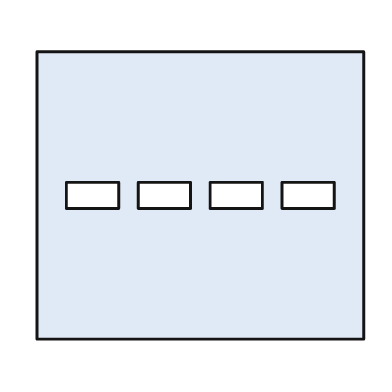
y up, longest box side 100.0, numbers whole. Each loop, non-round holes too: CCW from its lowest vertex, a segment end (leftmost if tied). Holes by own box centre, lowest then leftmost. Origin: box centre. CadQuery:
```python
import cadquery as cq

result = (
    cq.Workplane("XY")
    .moveTo(-50.0, -44.0)
    .lineTo(50.0, -44.0)
    .lineTo(50.0, 44.0)
    .lineTo(-50.0, 44.0)
    .close()
    .moveTo(-41.0, -4.0)
    .lineTo(-25.0, -4.0)
    .lineTo(-25.0, 4.0)
    .lineTo(-41.0, 4.0)
    .close()
    .moveTo(-19.0, -4.0)
    .lineTo(-3.0, -4.0)
    .lineTo(-3.0, 4.0)
    .lineTo(-19.0, 4.0)
    .close()
    .moveTo(3.0, -4.0)
    .lineTo(19.0, -4.0)
    .lineTo(19.0, 4.0)
    .lineTo(3.0, 4.0)
    .close()
    .moveTo(25.0, -4.0)
    .lineTo(41.0, -4.0)
    .lineTo(41.0, 4.0)
    .lineTo(25.0, 4.0)
    .close()
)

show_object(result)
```